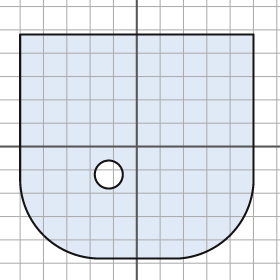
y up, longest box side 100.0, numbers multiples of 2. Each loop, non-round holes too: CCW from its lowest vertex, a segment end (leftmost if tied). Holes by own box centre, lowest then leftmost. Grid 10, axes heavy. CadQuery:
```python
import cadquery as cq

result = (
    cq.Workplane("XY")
    .moveTo(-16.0, -48.0)
    .lineTo(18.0, -48.0)
    .threePointArc((40.0, -38.0), (50.0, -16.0))
    .lineTo(50.0, 48.0)
    .lineTo(-50.0, 48.0)
    .lineTo(-50.0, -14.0)
    .threePointArc((-40.0, -38.0), (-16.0, -48.0))
    .close()
    .moveTo(-12.0, -12.0)
    .circle(6.0)
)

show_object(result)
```